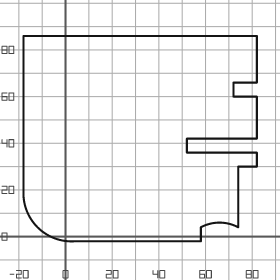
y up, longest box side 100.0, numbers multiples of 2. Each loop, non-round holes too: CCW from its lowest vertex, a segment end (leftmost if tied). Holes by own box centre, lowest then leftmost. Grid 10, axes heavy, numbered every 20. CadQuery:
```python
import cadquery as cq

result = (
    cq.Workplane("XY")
    .moveTo(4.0, -2.0)
    .lineTo(58.0, -2.0)
    .lineTo(58.0, 4.0)
    .threePointArc((66.0, 6.0), (74.0, 4.0))
    .lineTo(74.0, 30.0)
    .lineTo(82.0, 30.0)
    .lineTo(82.0, 36.0)
    .lineTo(52.0, 36.0)
    .lineTo(52.0, 42.0)
    .lineTo(82.0, 42.0)
    .lineTo(82.0, 60.0)
    .lineTo(72.0, 60.0)
    .lineTo(72.0, 66.0)
    .lineTo(82.0, 66.0)
    .lineTo(82.0, 86.0)
    .lineTo(-18.0, 86.0)
    .lineTo(-18.0, 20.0)
    .threePointArc((-12.0, 4.0), (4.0, -2.0))
    .close()
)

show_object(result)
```